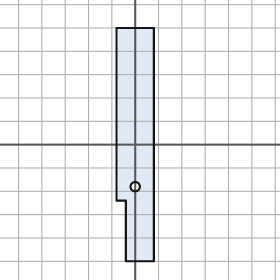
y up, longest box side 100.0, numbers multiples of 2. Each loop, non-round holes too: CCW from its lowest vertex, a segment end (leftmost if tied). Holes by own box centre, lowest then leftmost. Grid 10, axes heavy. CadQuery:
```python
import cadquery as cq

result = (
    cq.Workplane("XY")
    .moveTo(-4.0, -50.0)
    .lineTo(8.0, -50.0)
    .lineTo(8.0, 50.0)
    .lineTo(-8.0, 50.0)
    .lineTo(-8.0, -24.0)
    .lineTo(-4.0, -24.0)
    .close()
    .moveTo(0.0, -18.0)
    .circle(2.0)
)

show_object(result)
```